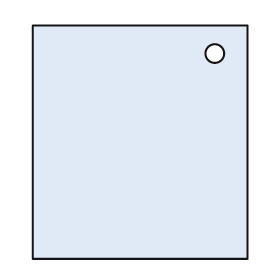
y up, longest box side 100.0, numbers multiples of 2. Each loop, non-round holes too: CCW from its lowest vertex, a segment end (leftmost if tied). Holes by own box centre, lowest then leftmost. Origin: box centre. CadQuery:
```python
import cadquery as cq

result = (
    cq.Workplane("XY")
    .moveTo(-46.0, -50.0)
    .lineTo(46.0, -50.0)
    .lineTo(46.0, 50.0)
    .lineTo(-46.0, 50.0)
    .close()
    .moveTo(32.0, 38.0)
    .circle(4.0)
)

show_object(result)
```